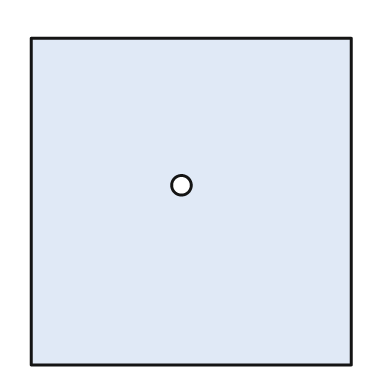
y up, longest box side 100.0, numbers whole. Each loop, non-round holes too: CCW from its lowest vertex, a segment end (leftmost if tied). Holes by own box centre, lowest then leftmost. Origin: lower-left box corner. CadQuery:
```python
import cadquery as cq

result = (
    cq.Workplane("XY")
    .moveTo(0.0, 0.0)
    .lineTo(98.0, 0.0)
    .lineTo(98.0, 100.0)
    .lineTo(0.0, 100.0)
    .close()
    .moveTo(46.0, 55.0)
    .circle(3.0)
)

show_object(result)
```